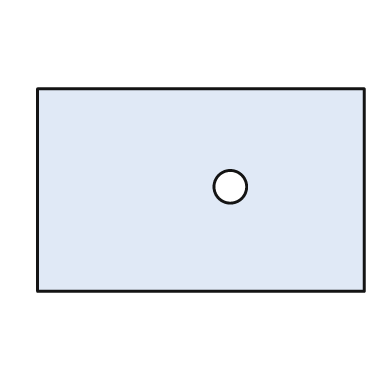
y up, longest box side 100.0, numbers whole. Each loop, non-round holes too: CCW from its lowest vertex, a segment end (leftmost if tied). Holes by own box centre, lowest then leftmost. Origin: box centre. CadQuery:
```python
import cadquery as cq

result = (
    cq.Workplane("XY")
    .moveTo(-50.0, -31.0)
    .lineTo(50.0, -31.0)
    .lineTo(50.0, 31.0)
    .lineTo(-50.0, 31.0)
    .close()
    .moveTo(9.0, 1.0)
    .circle(5.0)
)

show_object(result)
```